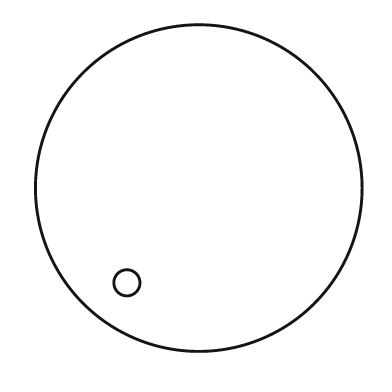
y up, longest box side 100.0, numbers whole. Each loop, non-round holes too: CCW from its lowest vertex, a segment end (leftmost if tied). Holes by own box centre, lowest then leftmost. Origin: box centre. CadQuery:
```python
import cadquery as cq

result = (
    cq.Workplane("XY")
    .moveTo(0.0, 0.0)
    .circle(50.0)
    .moveTo(-22.0, -29.0)
    .circle(4.0)
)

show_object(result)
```